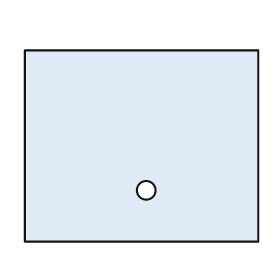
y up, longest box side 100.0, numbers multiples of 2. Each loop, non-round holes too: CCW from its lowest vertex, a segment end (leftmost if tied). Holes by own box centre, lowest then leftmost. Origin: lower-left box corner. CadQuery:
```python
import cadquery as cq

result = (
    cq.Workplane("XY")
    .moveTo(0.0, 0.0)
    .lineTo(100.0, 0.0)
    .lineTo(100.0, 82.0)
    .lineTo(0.0, 82.0)
    .close()
    .moveTo(52.0, 22.0)
    .circle(4.0)
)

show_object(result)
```